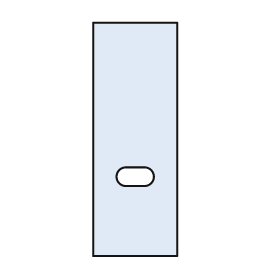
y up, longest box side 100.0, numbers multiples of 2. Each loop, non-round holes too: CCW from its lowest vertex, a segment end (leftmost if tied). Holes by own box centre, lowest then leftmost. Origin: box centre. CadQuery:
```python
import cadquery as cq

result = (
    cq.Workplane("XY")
    .moveTo(-18.0, -50.0)
    .lineTo(18.0, -50.0)
    .lineTo(18.0, 50.0)
    .lineTo(-18.0, 50.0)
    .close()
    .moveTo(-4.0, -20.0)
    .lineTo(4.0, -20.0)
    .threePointArc((8.0, -16.0), (4.0, -12.0))
    .lineTo(-4.0, -12.0)
    .threePointArc((-8.0, -16.0), (-4.0, -20.0))
    .close()
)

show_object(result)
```